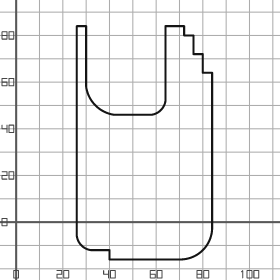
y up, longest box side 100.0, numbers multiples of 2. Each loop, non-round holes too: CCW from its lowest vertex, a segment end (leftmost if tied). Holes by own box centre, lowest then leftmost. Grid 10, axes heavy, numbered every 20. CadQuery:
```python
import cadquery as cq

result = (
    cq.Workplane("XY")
    .moveTo(40.0, -16.0)
    .lineTo(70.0, -16.0)
    .threePointArc((80.0, -12.0), (84.0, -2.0))
    .lineTo(84.0, 64.0)
    .lineTo(80.0, 64.0)
    .lineTo(80.0, 72.0)
    .lineTo(76.0, 72.0)
    .lineTo(76.0, 80.0)
    .lineTo(72.0, 80.0)
    .lineTo(72.0, 84.0)
    .lineTo(64.0, 84.0)
    .lineTo(64.0, 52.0)
    .threePointArc((62.0, 48.0), (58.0, 46.0))
    .lineTo(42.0, 46.0)
    .threePointArc((34.0, 50.0), (30.0, 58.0))
    .lineTo(30.0, 84.0)
    .lineTo(26.0, 84.0)
    .lineTo(26.0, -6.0)
    .threePointArc((28.0, -10.0), (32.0, -12.0))
    .lineTo(40.0, -12.0)
    .close()
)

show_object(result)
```